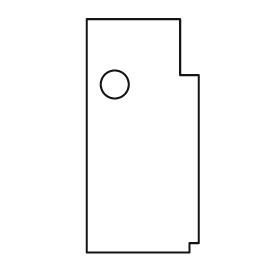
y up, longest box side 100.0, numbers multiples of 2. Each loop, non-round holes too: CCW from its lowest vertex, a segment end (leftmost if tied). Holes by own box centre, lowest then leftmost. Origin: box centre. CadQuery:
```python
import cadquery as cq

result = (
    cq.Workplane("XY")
    .moveTo(-24.0, -50.0)
    .lineTo(20.0, -50.0)
    .lineTo(20.0, -46.0)
    .lineTo(24.0, -46.0)
    .lineTo(24.0, 26.0)
    .lineTo(16.0, 26.0)
    .lineTo(16.0, 50.0)
    .lineTo(-24.0, 50.0)
    .close()
    .moveTo(-12.0, 22.0)
    .circle(6.0)
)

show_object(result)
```